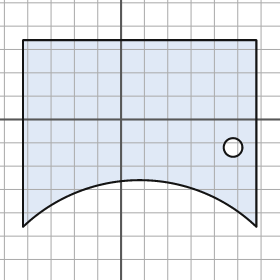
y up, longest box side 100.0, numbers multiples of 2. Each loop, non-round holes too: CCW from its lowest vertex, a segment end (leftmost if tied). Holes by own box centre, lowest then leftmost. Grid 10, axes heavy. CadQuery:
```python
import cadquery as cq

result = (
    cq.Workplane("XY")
    .moveTo(-42.0, -46.0)
    .threePointArc((8.0, -26.0), (58.0, -46.0))
    .lineTo(58.0, 34.0)
    .lineTo(-42.0, 34.0)
    .close()
    .moveTo(48.0, -12.0)
    .circle(4.0)
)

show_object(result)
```